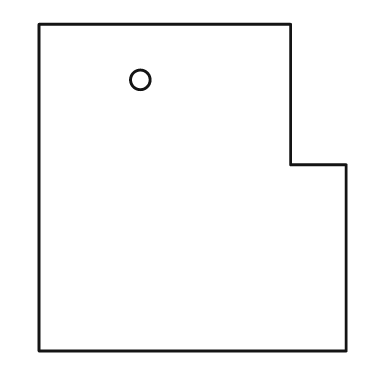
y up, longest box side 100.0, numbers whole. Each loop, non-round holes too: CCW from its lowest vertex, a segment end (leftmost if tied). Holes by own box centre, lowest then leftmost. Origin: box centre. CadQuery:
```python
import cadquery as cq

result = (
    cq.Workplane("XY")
    .moveTo(-47.0, -50.0)
    .lineTo(47.0, -50.0)
    .lineTo(47.0, 7.0)
    .lineTo(30.0, 7.0)
    .lineTo(30.0, 50.0)
    .lineTo(-47.0, 50.0)
    .close()
    .moveTo(-16.0, 33.0)
    .circle(3.0)
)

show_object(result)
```